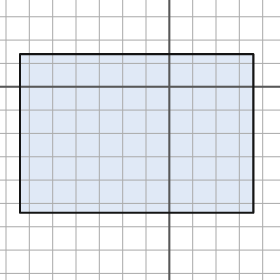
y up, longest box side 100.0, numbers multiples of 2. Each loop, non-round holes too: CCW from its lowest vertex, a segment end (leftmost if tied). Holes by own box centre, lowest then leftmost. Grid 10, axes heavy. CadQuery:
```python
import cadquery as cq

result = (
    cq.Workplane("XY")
    .moveTo(-64.0, -54.0)
    .lineTo(36.0, -54.0)
    .lineTo(36.0, 14.0)
    .lineTo(-64.0, 14.0)
    .close()
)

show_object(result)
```